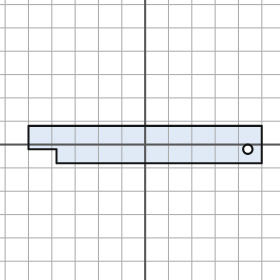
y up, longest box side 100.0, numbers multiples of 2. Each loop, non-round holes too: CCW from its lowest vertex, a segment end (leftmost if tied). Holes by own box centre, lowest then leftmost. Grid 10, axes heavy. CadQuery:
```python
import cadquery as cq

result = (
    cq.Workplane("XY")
    .moveTo(-38.0, -8.0)
    .lineTo(50.0, -8.0)
    .lineTo(50.0, 8.0)
    .lineTo(-50.0, 8.0)
    .lineTo(-50.0, -2.0)
    .lineTo(-38.0, -2.0)
    .close()
    .moveTo(44.0, -2.0)
    .circle(2.0)
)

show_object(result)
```